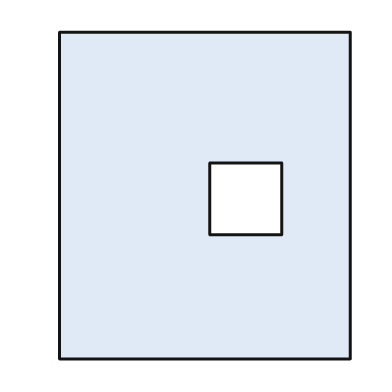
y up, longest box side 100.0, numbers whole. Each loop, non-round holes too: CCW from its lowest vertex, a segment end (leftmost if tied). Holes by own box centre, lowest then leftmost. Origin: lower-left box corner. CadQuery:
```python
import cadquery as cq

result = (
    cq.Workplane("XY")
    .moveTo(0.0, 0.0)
    .lineTo(89.0, 0.0)
    .lineTo(89.0, 100.0)
    .lineTo(0.0, 100.0)
    .close()
    .moveTo(46.0, 38.0)
    .lineTo(68.0, 38.0)
    .lineTo(68.0, 60.0)
    .lineTo(46.0, 60.0)
    .close()
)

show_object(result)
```